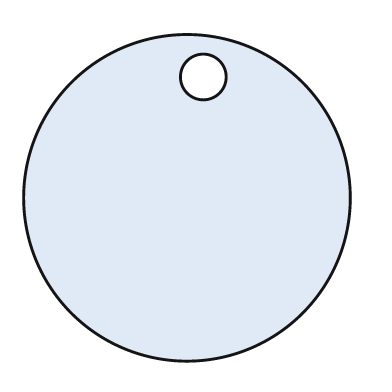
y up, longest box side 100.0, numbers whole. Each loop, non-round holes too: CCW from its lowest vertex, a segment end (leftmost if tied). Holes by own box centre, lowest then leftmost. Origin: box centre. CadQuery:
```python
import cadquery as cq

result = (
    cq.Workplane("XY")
    .moveTo(0.0, 0.0)
    .circle(50.0)
    .moveTo(5.0, 37.0)
    .circle(7.0)
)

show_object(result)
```